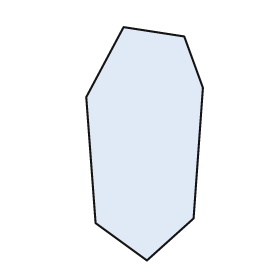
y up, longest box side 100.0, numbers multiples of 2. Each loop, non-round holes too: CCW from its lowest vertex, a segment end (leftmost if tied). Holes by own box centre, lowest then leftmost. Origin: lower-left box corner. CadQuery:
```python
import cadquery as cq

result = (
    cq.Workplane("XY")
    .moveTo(26.0, 0.0)
    .lineTo(46.0, 18.0)
    .lineTo(50.0, 74.0)
    .lineTo(42.0, 96.0)
    .lineTo(16.0, 100.0)
    .lineTo(0.0, 70.0)
    .lineTo(4.0, 16.0)
    .close()
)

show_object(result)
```